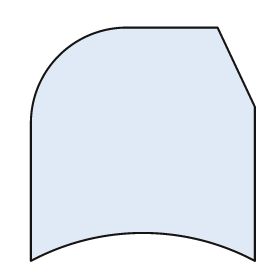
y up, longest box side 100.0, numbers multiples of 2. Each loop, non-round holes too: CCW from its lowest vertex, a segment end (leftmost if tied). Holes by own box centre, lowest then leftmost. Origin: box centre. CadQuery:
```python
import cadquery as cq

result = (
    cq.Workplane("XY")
    .moveTo(-48.0, -50.0)
    .threePointArc((0.0, -38.0), (48.0, -50.0))
    .lineTo(48.0, 16.0)
    .lineTo(32.0, 50.0)
    .lineTo(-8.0, 50.0)
    .threePointArc((-36.0, 38.0), (-48.0, 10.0))
    .close()
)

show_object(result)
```